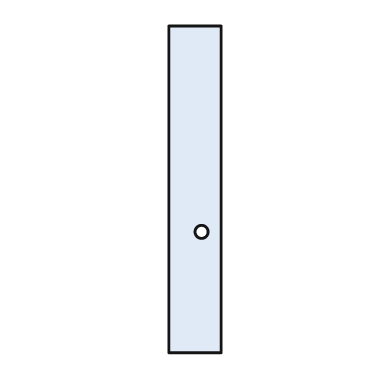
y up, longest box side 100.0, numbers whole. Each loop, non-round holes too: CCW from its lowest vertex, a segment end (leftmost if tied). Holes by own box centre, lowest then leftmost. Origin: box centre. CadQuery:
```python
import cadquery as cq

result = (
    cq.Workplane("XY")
    .moveTo(-8.0, -50.0)
    .lineTo(8.0, -50.0)
    .lineTo(8.0, 50.0)
    .lineTo(-8.0, 50.0)
    .close()
    .moveTo(2.0, -13.0)
    .circle(2.0)
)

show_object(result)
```